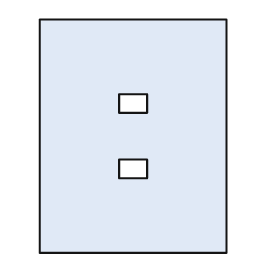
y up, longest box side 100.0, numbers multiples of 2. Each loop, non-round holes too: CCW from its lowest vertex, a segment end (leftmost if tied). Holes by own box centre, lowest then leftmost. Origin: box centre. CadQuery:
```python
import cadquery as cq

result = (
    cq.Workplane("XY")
    .moveTo(-40.0, -50.0)
    .lineTo(40.0, -50.0)
    .lineTo(40.0, 50.0)
    .lineTo(-40.0, 50.0)
    .close()
    .moveTo(-6.0, -18.0)
    .lineTo(6.0, -18.0)
    .lineTo(6.0, -10.0)
    .lineTo(-6.0, -10.0)
    .close()
    .moveTo(-6.0, 10.0)
    .lineTo(6.0, 10.0)
    .lineTo(6.0, 18.0)
    .lineTo(-6.0, 18.0)
    .close()
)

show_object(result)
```